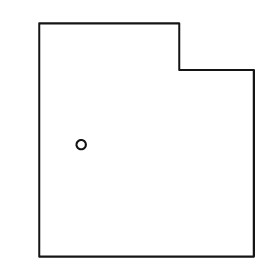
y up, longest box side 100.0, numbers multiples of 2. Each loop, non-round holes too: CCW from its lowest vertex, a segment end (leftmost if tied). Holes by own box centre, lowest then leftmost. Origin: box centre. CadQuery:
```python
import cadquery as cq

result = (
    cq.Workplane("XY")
    .moveTo(-46.0, -50.0)
    .lineTo(46.0, -50.0)
    .lineTo(46.0, 30.0)
    .lineTo(14.0, 30.0)
    .lineTo(14.0, 50.0)
    .lineTo(-46.0, 50.0)
    .close()
    .moveTo(-28.0, -2.0)
    .circle(2.0)
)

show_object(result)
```